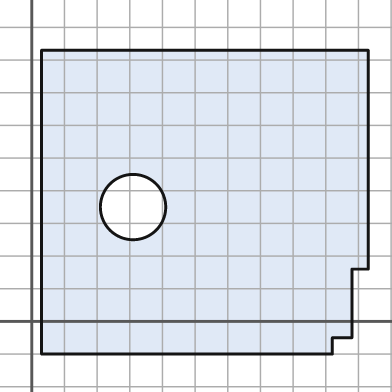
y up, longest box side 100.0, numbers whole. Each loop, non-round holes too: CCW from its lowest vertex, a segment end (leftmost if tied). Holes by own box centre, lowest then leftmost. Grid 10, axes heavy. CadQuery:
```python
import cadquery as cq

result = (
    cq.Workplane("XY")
    .moveTo(3.0, -10.0)
    .lineTo(92.0, -10.0)
    .lineTo(92.0, -5.0)
    .lineTo(98.0, -5.0)
    .lineTo(98.0, 16.0)
    .lineTo(103.0, 16.0)
    .lineTo(103.0, 83.0)
    .lineTo(3.0, 83.0)
    .close()
    .moveTo(31.0, 35.0)
    .circle(10.0)
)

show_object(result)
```